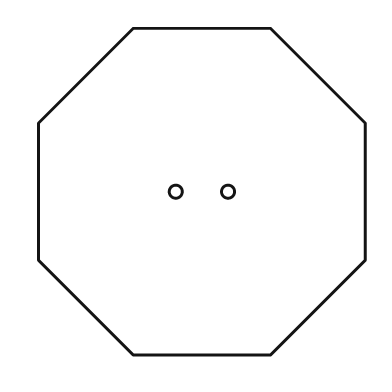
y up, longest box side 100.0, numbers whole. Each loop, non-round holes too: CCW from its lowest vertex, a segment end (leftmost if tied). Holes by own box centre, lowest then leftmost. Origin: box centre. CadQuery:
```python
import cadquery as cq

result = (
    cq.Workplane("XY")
    .moveTo(-21.0, -50.0)
    .lineTo(21.0, -50.0)
    .lineTo(50.0, -21.0)
    .lineTo(50.0, 21.0)
    .lineTo(21.0, 50.0)
    .lineTo(-21.0, 50.0)
    .lineTo(-50.0, 21.0)
    .lineTo(-50.0, -21.0)
    .close()
    .moveTo(-8.0, 0.0)
    .circle(2.0)
    .moveTo(8.0, 0.0)
    .circle(2.0)
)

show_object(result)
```